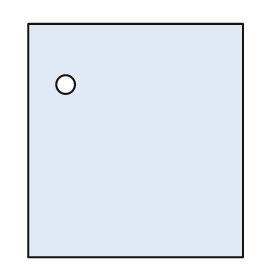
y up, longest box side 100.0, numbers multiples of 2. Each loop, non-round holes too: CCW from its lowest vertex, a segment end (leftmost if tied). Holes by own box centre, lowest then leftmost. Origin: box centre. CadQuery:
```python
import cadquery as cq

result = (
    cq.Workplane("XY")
    .moveTo(-46.0, -50.0)
    .lineTo(46.0, -50.0)
    .lineTo(46.0, 50.0)
    .lineTo(-46.0, 50.0)
    .close()
    .moveTo(-30.0, 24.0)
    .circle(4.0)
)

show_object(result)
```